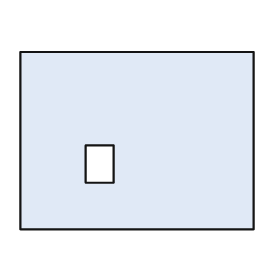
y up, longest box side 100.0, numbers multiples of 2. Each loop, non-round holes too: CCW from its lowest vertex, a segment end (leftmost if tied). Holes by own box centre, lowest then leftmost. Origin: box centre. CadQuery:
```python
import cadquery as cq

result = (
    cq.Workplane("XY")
    .moveTo(-50.0, -38.0)
    .lineTo(50.0, -38.0)
    .lineTo(50.0, 38.0)
    .lineTo(-50.0, 38.0)
    .close()
    .moveTo(-22.0, -18.0)
    .lineTo(-10.0, -18.0)
    .lineTo(-10.0, -2.0)
    .lineTo(-22.0, -2.0)
    .close()
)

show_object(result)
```